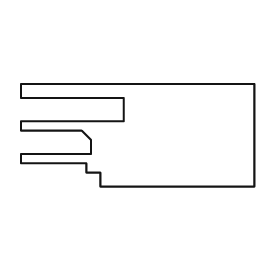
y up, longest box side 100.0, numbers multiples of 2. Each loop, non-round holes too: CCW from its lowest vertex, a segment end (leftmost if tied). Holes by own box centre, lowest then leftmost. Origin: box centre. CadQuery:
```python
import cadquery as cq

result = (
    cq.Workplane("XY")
    .moveTo(-16.0, -22.0)
    .lineTo(50.0, -22.0)
    .lineTo(50.0, 22.0)
    .lineTo(-50.0, 22.0)
    .lineTo(-50.0, 16.0)
    .lineTo(-6.0, 16.0)
    .lineTo(-6.0, 6.0)
    .lineTo(-50.0, 6.0)
    .lineTo(-50.0, 2.0)
    .lineTo(-24.0, 2.0)
    .lineTo(-20.0, -2.0)
    .lineTo(-20.0, -8.0)
    .lineTo(-50.0, -8.0)
    .lineTo(-50.0, -12.0)
    .lineTo(-22.0, -12.0)
    .lineTo(-22.0, -16.0)
    .lineTo(-16.0, -16.0)
    .close()
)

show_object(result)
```